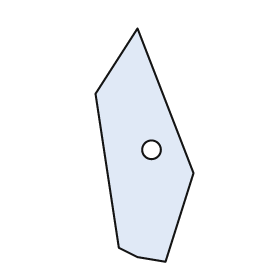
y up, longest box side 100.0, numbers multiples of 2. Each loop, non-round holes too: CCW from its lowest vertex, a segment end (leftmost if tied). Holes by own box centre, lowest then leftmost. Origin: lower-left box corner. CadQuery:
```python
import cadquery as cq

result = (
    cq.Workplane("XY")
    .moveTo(30.0, 0.0)
    .lineTo(42.0, 38.0)
    .lineTo(18.0, 100.0)
    .lineTo(0.0, 72.0)
    .lineTo(10.0, 6.0)
    .lineTo(18.0, 2.0)
    .close()
    .moveTo(24.0, 48.0)
    .circle(4.0)
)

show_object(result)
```